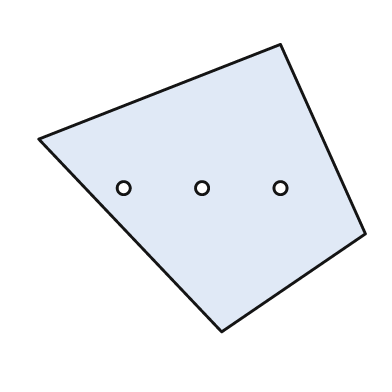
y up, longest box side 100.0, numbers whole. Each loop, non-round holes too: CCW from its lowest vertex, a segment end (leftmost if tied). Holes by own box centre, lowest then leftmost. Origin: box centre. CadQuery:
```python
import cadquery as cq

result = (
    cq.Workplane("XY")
    .moveTo(6.0, -44.0)
    .lineTo(50.0, -14.0)
    .lineTo(24.0, 44.0)
    .lineTo(-50.0, 15.0)
    .close()
    .moveTo(-24.0, 0.0)
    .circle(2.0)
    .moveTo(0.0, 0.0)
    .circle(2.0)
    .moveTo(24.0, 0.0)
    .circle(2.0)
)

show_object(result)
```